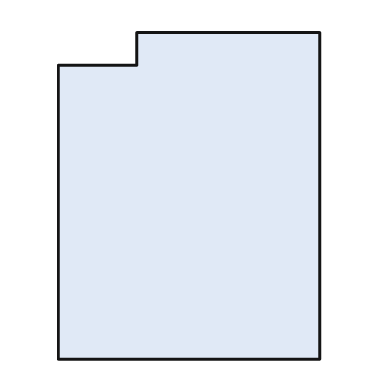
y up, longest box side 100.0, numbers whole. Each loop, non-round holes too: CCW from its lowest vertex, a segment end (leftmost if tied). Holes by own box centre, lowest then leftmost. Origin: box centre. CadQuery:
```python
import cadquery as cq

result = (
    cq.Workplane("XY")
    .moveTo(-40.0, -50.0)
    .lineTo(40.0, -50.0)
    .lineTo(40.0, 50.0)
    .lineTo(-16.0, 50.0)
    .lineTo(-16.0, 40.0)
    .lineTo(-40.0, 40.0)
    .close()
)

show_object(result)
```